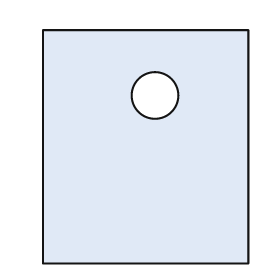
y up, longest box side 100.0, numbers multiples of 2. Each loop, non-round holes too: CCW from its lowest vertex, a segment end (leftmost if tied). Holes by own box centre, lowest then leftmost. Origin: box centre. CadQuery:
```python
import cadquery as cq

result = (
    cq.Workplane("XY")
    .moveTo(-44.0, -50.0)
    .lineTo(44.0, -50.0)
    .lineTo(44.0, 50.0)
    .lineTo(-44.0, 50.0)
    .close()
    .moveTo(4.0, 22.0)
    .circle(10.0)
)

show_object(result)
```